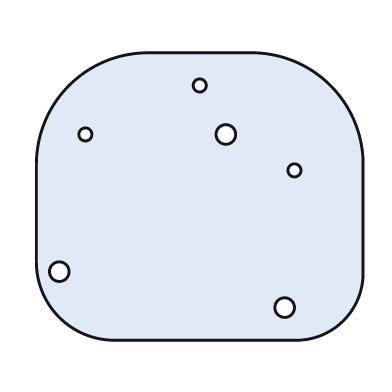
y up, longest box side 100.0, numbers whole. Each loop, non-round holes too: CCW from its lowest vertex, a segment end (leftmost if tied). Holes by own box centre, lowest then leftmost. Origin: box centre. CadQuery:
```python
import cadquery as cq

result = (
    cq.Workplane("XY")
    .moveTo(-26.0, -44.0)
    .lineTo(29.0, -44.0)
    .threePointArc((44.0, -38.0), (50.0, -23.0))
    .lineTo(50.0, 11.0)
    .threePointArc((40.0, 34.0), (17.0, 44.0))
    .lineTo(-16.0, 44.0)
    .threePointArc((-40.0, 34.0), (-50.0, 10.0))
    .lineTo(-50.0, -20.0)
    .threePointArc((-43.0, -37.0), (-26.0, -44.0))
    .close()
    .moveTo(26.0, -34.0)
    .circle(3.0)
    .moveTo(-43.0, -23.0)
    .circle(3.0)
    .moveTo(29.0, 8.0)
    .circle(2.0)
    .moveTo(-35.0, 19.0)
    .circle(2.0)
    .moveTo(8.0, 19.0)
    .circle(3.0)
    .moveTo(0.0, 34.0)
    .circle(2.0)
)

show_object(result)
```